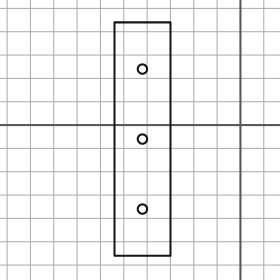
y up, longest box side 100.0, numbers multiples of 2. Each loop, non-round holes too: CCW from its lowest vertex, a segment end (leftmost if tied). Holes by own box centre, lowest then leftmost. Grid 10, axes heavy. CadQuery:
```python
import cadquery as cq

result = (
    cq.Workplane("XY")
    .moveTo(-54.0, -56.0)
    .lineTo(-30.0, -56.0)
    .lineTo(-30.0, 44.0)
    .lineTo(-54.0, 44.0)
    .close()
    .moveTo(-42.0, -36.0)
    .circle(2.0)
    .moveTo(-42.0, -6.0)
    .circle(2.0)
    .moveTo(-42.0, 24.0)
    .circle(2.0)
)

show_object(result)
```